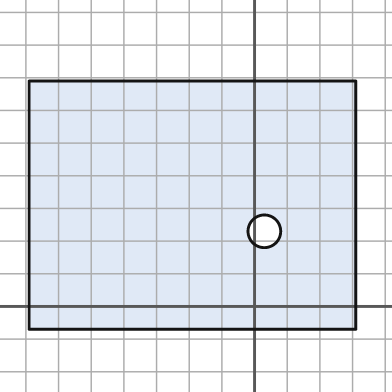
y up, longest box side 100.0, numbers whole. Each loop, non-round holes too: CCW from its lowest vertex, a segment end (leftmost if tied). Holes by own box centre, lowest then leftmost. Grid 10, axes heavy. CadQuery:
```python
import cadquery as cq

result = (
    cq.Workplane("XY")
    .moveTo(-69.0, -7.0)
    .lineTo(31.0, -7.0)
    .lineTo(31.0, 69.0)
    .lineTo(-69.0, 69.0)
    .close()
    .moveTo(3.0, 23.0)
    .circle(5.0)
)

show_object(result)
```